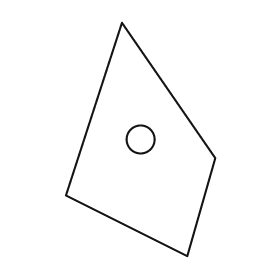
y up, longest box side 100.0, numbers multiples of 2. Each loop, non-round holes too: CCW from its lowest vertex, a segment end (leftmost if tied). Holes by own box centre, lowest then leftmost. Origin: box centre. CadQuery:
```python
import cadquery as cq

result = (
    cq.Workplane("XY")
    .moveTo(20.0, -50.0)
    .lineTo(32.0, -8.0)
    .lineTo(-8.0, 50.0)
    .lineTo(-32.0, -24.0)
    .close()
    .moveTo(0.0, 0.0)
    .circle(6.0)
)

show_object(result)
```